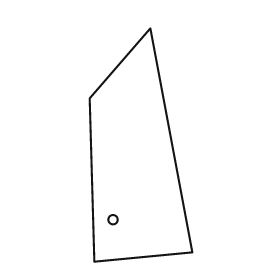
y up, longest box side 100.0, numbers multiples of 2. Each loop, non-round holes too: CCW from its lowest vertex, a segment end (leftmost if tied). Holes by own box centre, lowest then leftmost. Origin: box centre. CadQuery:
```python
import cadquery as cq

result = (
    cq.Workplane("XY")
    .moveTo(-20.0, -50.0)
    .lineTo(22.0, -46.0)
    .lineTo(4.0, 50.0)
    .lineTo(-22.0, 20.0)
    .close()
    .moveTo(-12.0, -32.0)
    .circle(2.0)
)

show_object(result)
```